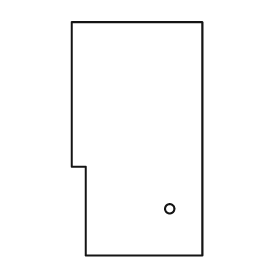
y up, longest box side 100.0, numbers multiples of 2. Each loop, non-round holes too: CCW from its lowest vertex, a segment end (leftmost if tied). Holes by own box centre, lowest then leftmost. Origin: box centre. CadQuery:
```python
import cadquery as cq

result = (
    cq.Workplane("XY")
    .moveTo(-22.0, -50.0)
    .lineTo(28.0, -50.0)
    .lineTo(28.0, 50.0)
    .lineTo(-28.0, 50.0)
    .lineTo(-28.0, -12.0)
    .lineTo(-22.0, -12.0)
    .close()
    .moveTo(14.0, -30.0)
    .circle(2.0)
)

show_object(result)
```